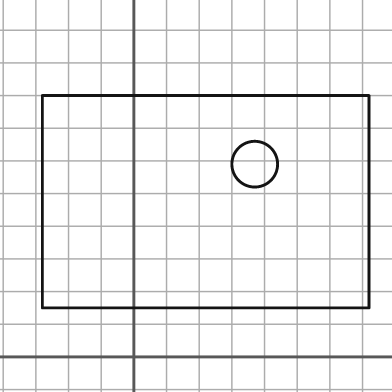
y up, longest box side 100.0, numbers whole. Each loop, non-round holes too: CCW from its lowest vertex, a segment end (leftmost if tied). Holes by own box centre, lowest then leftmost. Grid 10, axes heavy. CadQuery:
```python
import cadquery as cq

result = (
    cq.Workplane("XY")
    .moveTo(-28.0, 15.0)
    .lineTo(72.0, 15.0)
    .lineTo(72.0, 80.0)
    .lineTo(-28.0, 80.0)
    .close()
    .moveTo(37.0, 59.0)
    .circle(7.0)
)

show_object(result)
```